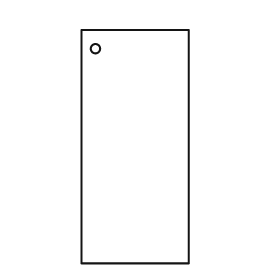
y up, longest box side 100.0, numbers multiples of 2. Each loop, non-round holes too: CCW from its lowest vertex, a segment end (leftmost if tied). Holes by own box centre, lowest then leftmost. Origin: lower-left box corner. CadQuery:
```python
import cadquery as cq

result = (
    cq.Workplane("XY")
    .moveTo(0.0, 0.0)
    .lineTo(46.0, 0.0)
    .lineTo(46.0, 100.0)
    .lineTo(0.0, 100.0)
    .close()
    .moveTo(6.0, 92.0)
    .circle(2.0)
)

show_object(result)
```